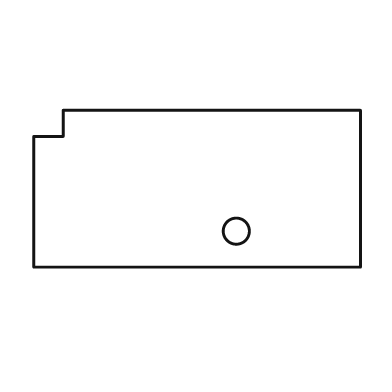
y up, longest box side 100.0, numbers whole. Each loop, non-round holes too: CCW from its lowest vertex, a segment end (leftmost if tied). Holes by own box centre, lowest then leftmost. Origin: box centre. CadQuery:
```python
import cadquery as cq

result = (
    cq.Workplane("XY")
    .moveTo(-50.0, -24.0)
    .lineTo(50.0, -24.0)
    .lineTo(50.0, 24.0)
    .lineTo(-41.0, 24.0)
    .lineTo(-41.0, 16.0)
    .lineTo(-50.0, 16.0)
    .close()
    .moveTo(12.0, -13.0)
    .circle(4.0)
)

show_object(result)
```